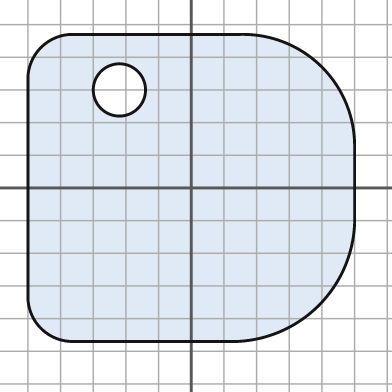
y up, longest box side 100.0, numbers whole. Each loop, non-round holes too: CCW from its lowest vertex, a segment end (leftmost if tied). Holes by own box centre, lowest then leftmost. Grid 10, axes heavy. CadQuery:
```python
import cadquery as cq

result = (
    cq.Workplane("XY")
    .moveTo(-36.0, -47.0)
    .lineTo(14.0, -47.0)
    .threePointArc((39.0, -36.0), (50.0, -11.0))
    .lineTo(50.0, 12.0)
    .threePointArc((40.0, 37.0), (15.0, 47.0))
    .lineTo(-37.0, 47.0)
    .threePointArc((-46.0, 43.0), (-50.0, 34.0))
    .lineTo(-50.0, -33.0)
    .threePointArc((-46.0, -43.0), (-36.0, -47.0))
    .close()
    .moveTo(-22.0, 30.0)
    .circle(8.0)
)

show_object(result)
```